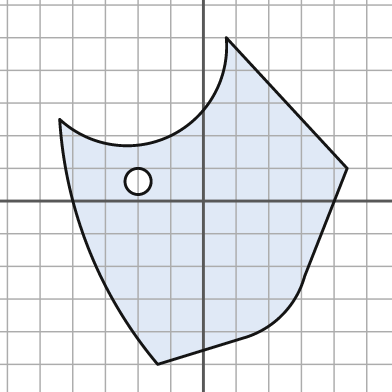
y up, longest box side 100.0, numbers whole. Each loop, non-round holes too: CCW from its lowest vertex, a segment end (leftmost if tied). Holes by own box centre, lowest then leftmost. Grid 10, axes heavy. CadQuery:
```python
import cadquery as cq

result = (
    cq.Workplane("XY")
    .moveTo(-14.0, -50.0)
    .lineTo(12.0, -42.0)
    .threePointArc((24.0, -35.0), (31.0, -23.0))
    .lineTo(44.0, 10.0)
    .lineTo(7.0, 50.0)
    .threePointArc((-10.0, 20.0), (-44.0, 25.0))
    .threePointArc((-35.0, -15.0), (-14.0, -50.0))
    .close()
    .moveTo(-20.0, 6.0)
    .circle(4.0)
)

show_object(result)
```